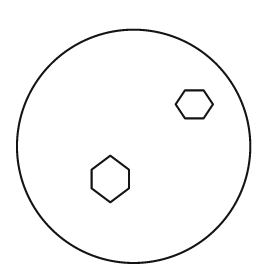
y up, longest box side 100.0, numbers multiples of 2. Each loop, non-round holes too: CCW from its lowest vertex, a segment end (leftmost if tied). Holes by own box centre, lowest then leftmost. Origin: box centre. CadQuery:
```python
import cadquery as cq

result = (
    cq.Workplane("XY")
    .moveTo(0.0, 0.0)
    .circle(50.0)
    .moveTo(-10.0, -24.0)
    .lineTo(-2.0, -18.0)
    .lineTo(-2.0, -10.0)
    .lineTo(-10.0, -4.0)
    .lineTo(-18.0, -10.0)
    .lineTo(-18.0, -18.0)
    .close()
    .moveTo(22.0, 12.0)
    .lineTo(30.0, 12.0)
    .lineTo(34.0, 18.0)
    .lineTo(30.0, 24.0)
    .lineTo(22.0, 24.0)
    .lineTo(18.0, 18.0)
    .close()
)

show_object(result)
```